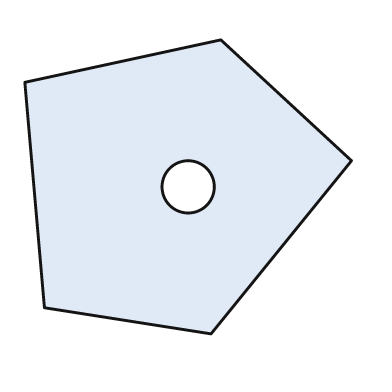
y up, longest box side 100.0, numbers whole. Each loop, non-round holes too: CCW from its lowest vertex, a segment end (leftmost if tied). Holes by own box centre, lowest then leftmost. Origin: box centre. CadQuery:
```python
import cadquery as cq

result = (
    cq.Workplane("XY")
    .moveTo(7.0, -45.0)
    .lineTo(50.0, 8.0)
    .lineTo(10.0, 45.0)
    .lineTo(-50.0, 32.0)
    .lineTo(-44.0, -37.0)
    .close()
    .moveTo(0.0, 0.0)
    .circle(8.0)
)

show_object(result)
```